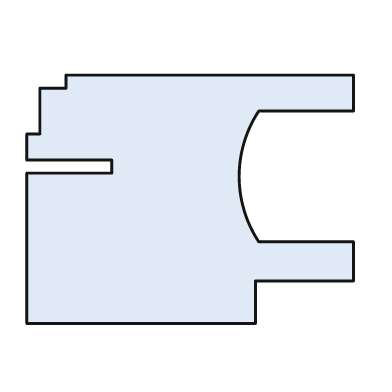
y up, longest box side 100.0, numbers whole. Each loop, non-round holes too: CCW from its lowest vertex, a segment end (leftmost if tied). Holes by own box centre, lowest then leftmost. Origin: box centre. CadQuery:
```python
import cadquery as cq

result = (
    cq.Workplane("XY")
    .moveTo(-50.0, -38.0)
    .lineTo(20.0, -38.0)
    .lineTo(20.0, -25.0)
    .lineTo(50.0, -25.0)
    .lineTo(50.0, -13.0)
    .lineTo(21.0, -13.0)
    .threePointArc((15.0, 7.0), (21.0, 27.0))
    .lineTo(50.0, 27.0)
    .lineTo(50.0, 38.0)
    .lineTo(-38.0, 38.0)
    .lineTo(-38.0, 34.0)
    .lineTo(-46.0, 34.0)
    .lineTo(-46.0, 20.0)
    .lineTo(-50.0, 20.0)
    .lineTo(-50.0, 12.0)
    .lineTo(-24.0, 12.0)
    .lineTo(-24.0, 8.0)
    .lineTo(-50.0, 8.0)
    .close()
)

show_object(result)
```